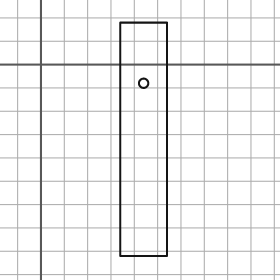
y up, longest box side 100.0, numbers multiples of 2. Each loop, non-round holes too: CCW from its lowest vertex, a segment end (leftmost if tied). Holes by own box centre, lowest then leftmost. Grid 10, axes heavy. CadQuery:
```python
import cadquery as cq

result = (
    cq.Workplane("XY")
    .moveTo(34.0, -82.0)
    .lineTo(54.0, -82.0)
    .lineTo(54.0, 18.0)
    .lineTo(34.0, 18.0)
    .close()
    .moveTo(44.0, -8.0)
    .circle(2.0)
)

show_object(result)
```